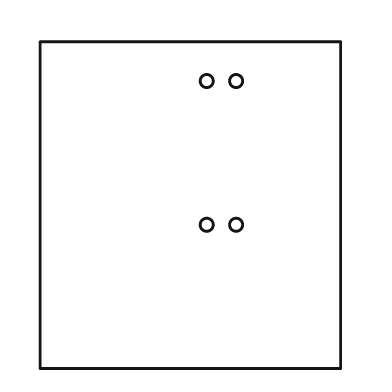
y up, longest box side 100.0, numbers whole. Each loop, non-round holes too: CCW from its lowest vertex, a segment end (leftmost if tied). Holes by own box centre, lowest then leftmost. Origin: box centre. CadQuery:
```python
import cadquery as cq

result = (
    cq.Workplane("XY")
    .moveTo(-46.0, -50.0)
    .lineTo(46.0, -50.0)
    .lineTo(46.0, 50.0)
    .lineTo(-46.0, 50.0)
    .close()
    .moveTo(5.0, -6.0)
    .circle(2.0)
    .moveTo(14.0, -6.0)
    .circle(2.0)
    .moveTo(5.0, 38.0)
    .circle(2.0)
    .moveTo(14.0, 38.0)
    .circle(2.0)
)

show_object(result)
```